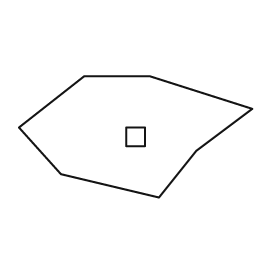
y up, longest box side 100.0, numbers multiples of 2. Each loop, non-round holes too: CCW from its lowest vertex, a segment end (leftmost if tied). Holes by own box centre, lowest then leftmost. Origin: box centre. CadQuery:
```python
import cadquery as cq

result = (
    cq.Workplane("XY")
    .moveTo(10.0, -26.0)
    .lineTo(26.0, -6.0)
    .lineTo(50.0, 12.0)
    .lineTo(6.0, 26.0)
    .lineTo(-22.0, 26.0)
    .lineTo(-50.0, 4.0)
    .lineTo(-32.0, -16.0)
    .close()
    .moveTo(-4.0, -4.0)
    .lineTo(4.0, -4.0)
    .lineTo(4.0, 4.0)
    .lineTo(-4.0, 4.0)
    .close()
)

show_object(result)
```